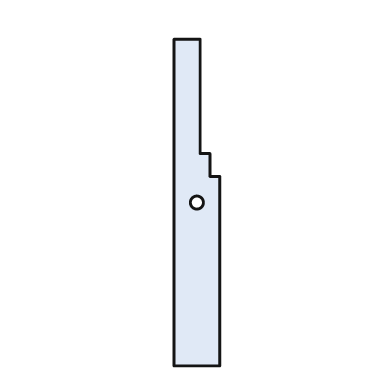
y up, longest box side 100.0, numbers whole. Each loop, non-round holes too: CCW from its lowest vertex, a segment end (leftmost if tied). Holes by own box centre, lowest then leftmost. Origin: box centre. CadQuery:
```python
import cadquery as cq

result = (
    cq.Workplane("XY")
    .moveTo(-7.0, -50.0)
    .lineTo(7.0, -50.0)
    .lineTo(7.0, 8.0)
    .lineTo(4.0, 8.0)
    .lineTo(4.0, 15.0)
    .lineTo(1.0, 15.0)
    .lineTo(1.0, 50.0)
    .lineTo(-7.0, 50.0)
    .close()
    .moveTo(0.0, 0.0)
    .circle(2.0)
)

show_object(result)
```